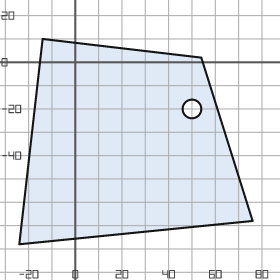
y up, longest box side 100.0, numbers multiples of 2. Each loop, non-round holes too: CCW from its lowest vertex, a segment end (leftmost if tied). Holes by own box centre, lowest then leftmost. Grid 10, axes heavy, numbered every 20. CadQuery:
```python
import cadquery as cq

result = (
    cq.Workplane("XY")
    .moveTo(-24.0, -78.0)
    .lineTo(76.0, -68.0)
    .lineTo(54.0, 2.0)
    .lineTo(-14.0, 10.0)
    .close()
    .moveTo(50.0, -20.0)
    .circle(4.0)
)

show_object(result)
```